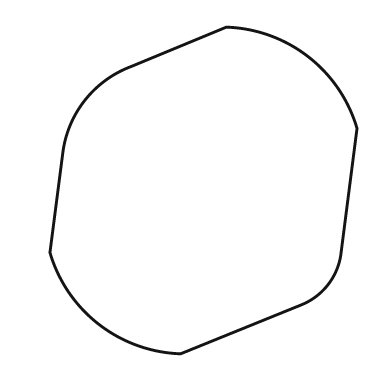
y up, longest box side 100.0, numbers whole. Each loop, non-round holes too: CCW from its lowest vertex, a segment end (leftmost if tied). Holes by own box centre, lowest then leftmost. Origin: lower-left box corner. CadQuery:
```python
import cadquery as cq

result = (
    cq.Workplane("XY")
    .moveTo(40.0, 0.0)
    .lineTo(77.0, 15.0)
    .threePointArc((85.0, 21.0), (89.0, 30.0))
    .lineTo(94.0, 69.0)
    .threePointArc((79.0, 91.0), (54.0, 100.0))
    .lineTo(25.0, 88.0)
    .threePointArc((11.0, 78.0), (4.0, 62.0))
    .lineTo(0.0, 31.0)
    .threePointArc((15.0, 9.0), (40.0, 0.0))
    .close()
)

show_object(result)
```